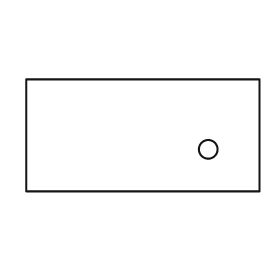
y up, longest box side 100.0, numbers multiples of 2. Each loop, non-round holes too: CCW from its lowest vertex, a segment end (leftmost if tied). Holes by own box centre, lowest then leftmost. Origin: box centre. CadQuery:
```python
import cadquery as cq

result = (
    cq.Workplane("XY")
    .moveTo(-50.0, -24.0)
    .lineTo(50.0, -24.0)
    .lineTo(50.0, 24.0)
    .lineTo(-50.0, 24.0)
    .close()
    .moveTo(28.0, -6.0)
    .circle(4.0)
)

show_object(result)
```